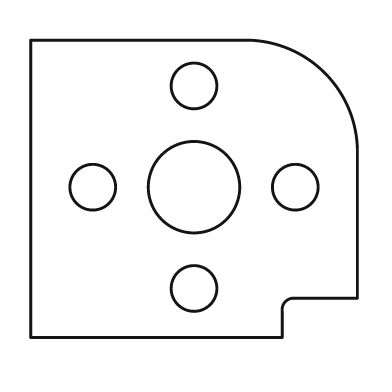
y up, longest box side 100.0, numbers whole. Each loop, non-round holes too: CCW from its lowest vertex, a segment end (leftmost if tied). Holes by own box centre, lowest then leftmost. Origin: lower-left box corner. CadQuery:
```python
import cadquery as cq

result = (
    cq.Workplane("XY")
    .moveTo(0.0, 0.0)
    .lineTo(77.0, 0.0)
    .lineTo(77.0, 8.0)
    .threePointArc((78.0, 11.0), (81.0, 12.0))
    .lineTo(100.0, 12.0)
    .lineTo(100.0, 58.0)
    .threePointArc((90.0, 81.0), (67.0, 91.0))
    .lineTo(0.0, 91.0)
    .close()
    .moveTo(50.0, 15.0)
    .circle(7.0)
    .moveTo(19.0, 46.0)
    .circle(7.0)
    .moveTo(50.0, 46.0)
    .circle(14.0)
    .moveTo(81.0, 46.0)
    .circle(7.0)
    .moveTo(50.0, 77.0)
    .circle(7.0)
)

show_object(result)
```